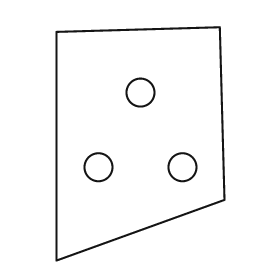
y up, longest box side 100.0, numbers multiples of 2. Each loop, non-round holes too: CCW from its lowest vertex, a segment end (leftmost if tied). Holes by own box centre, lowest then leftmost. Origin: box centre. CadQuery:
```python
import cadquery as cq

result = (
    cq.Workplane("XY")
    .moveTo(-36.0, -50.0)
    .lineTo(36.0, -24.0)
    .lineTo(34.0, 50.0)
    .lineTo(-36.0, 48.0)
    .close()
    .moveTo(-18.0, -10.0)
    .circle(6.0)
    .moveTo(18.0, -10.0)
    .circle(6.0)
    .moveTo(0.0, 22.0)
    .circle(6.0)
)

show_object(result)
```